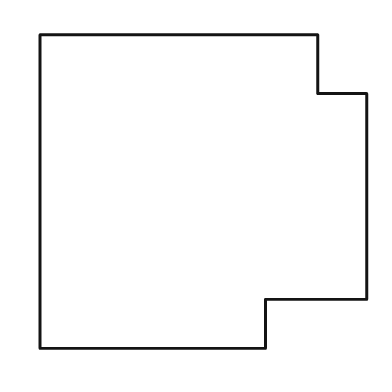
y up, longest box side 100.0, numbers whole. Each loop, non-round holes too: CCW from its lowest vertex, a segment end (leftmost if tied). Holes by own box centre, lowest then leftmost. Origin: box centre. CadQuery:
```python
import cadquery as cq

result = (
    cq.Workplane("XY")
    .moveTo(-50.0, -48.0)
    .lineTo(19.0, -48.0)
    .lineTo(19.0, -33.0)
    .lineTo(50.0, -33.0)
    .lineTo(50.0, 30.0)
    .lineTo(35.0, 30.0)
    .lineTo(35.0, 48.0)
    .lineTo(-50.0, 48.0)
    .close()
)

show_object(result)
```